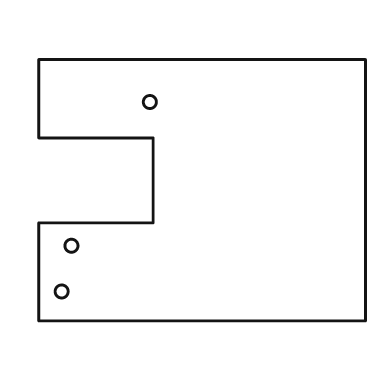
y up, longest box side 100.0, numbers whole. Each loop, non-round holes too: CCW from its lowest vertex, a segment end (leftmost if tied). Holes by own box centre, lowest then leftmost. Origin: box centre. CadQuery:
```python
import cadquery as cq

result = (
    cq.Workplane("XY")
    .moveTo(-50.0, -40.0)
    .lineTo(50.0, -40.0)
    .lineTo(50.0, 40.0)
    .lineTo(-50.0, 40.0)
    .lineTo(-50.0, 16.0)
    .lineTo(-15.0, 16.0)
    .lineTo(-15.0, -10.0)
    .lineTo(-50.0, -10.0)
    .close()
    .moveTo(-43.0, -31.0)
    .circle(2.0)
    .moveTo(-40.0, -17.0)
    .circle(2.0)
    .moveTo(-16.0, 27.0)
    .circle(2.0)
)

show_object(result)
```